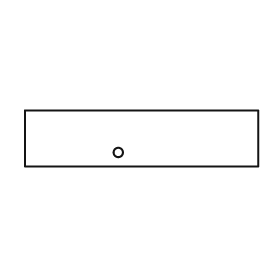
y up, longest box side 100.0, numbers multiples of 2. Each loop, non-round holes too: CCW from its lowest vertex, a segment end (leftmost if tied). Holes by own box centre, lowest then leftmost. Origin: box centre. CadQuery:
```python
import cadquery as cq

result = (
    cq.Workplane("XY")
    .moveTo(-50.0, -12.0)
    .lineTo(50.0, -12.0)
    .lineTo(50.0, 12.0)
    .lineTo(-50.0, 12.0)
    .close()
    .moveTo(-10.0, -6.0)
    .circle(2.0)
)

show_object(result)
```